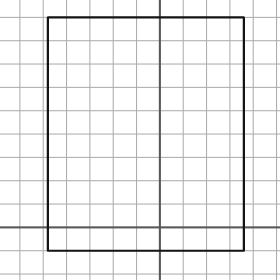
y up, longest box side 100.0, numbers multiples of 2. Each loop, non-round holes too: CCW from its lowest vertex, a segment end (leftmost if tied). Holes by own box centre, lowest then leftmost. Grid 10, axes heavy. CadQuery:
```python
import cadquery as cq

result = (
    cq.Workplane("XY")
    .moveTo(-48.0, -10.0)
    .lineTo(36.0, -10.0)
    .lineTo(36.0, 90.0)
    .lineTo(-48.0, 90.0)
    .close()
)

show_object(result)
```